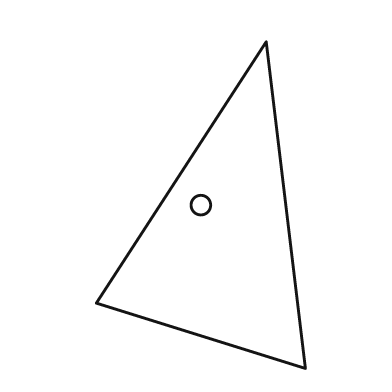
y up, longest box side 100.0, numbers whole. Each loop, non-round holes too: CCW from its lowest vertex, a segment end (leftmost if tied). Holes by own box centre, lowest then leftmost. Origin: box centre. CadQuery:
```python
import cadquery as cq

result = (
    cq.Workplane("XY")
    .moveTo(32.0, -50.0)
    .lineTo(20.0, 50.0)
    .lineTo(-32.0, -30.0)
    .close()
    .moveTo(0.0, 0.0)
    .circle(3.0)
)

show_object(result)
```